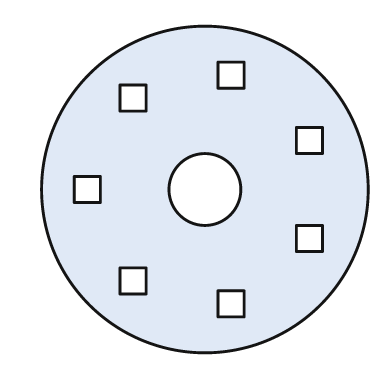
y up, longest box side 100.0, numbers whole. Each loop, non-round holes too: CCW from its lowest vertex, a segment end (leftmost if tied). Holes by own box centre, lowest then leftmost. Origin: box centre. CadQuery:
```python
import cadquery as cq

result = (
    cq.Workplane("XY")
    .moveTo(0.0, 0.0)
    .circle(50.0)
    .moveTo(4.0, -39.0)
    .lineTo(12.0, -39.0)
    .lineTo(12.0, -31.0)
    .lineTo(4.0, -31.0)
    .close()
    .moveTo(-26.0, -32.0)
    .lineTo(-18.0, -32.0)
    .lineTo(-18.0, -24.0)
    .lineTo(-26.0, -24.0)
    .close()
    .moveTo(28.0, -19.0)
    .lineTo(36.0, -19.0)
    .lineTo(36.0, -11.0)
    .lineTo(28.0, -11.0)
    .close()
    .moveTo(-40.0, -4.0)
    .lineTo(-32.0, -4.0)
    .lineTo(-32.0, 4.0)
    .lineTo(-40.0, 4.0)
    .close()
    .moveTo(0.0, 0.0)
    .circle(11.0)
    .moveTo(28.0, 11.0)
    .lineTo(36.0, 11.0)
    .lineTo(36.0, 19.0)
    .lineTo(28.0, 19.0)
    .close()
    .moveTo(-26.0, 24.0)
    .lineTo(-18.0, 24.0)
    .lineTo(-18.0, 32.0)
    .lineTo(-26.0, 32.0)
    .close()
    .moveTo(4.0, 31.0)
    .lineTo(12.0, 31.0)
    .lineTo(12.0, 39.0)
    .lineTo(4.0, 39.0)
    .close()
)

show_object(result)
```